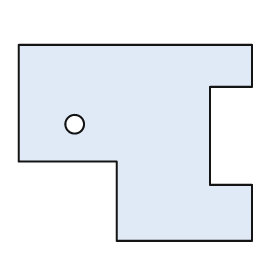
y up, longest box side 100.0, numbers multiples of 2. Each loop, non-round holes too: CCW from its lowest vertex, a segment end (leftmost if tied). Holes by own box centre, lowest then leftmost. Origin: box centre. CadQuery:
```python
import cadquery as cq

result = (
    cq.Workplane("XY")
    .moveTo(-8.0, -42.0)
    .lineTo(50.0, -42.0)
    .lineTo(50.0, -18.0)
    .lineTo(32.0, -18.0)
    .lineTo(32.0, 24.0)
    .lineTo(50.0, 24.0)
    .lineTo(50.0, 42.0)
    .lineTo(-50.0, 42.0)
    .lineTo(-50.0, -8.0)
    .lineTo(-8.0, -8.0)
    .close()
    .moveTo(-26.0, 8.0)
    .circle(4.0)
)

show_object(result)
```